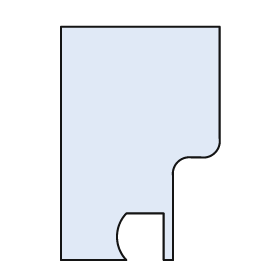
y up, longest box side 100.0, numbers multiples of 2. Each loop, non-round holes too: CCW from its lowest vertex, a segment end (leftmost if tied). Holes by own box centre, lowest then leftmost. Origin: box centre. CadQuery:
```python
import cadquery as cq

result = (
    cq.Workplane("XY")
    .moveTo(-34.0, -50.0)
    .lineTo(-6.0, -50.0)
    .threePointArc((-10.0, -40.0), (-6.0, -30.0))
    .lineTo(10.0, -30.0)
    .lineTo(10.0, -50.0)
    .lineTo(14.0, -50.0)
    .lineTo(14.0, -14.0)
    .threePointArc((16.0, -8.0), (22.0, -6.0))
    .lineTo(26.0, -6.0)
    .threePointArc((32.0, -4.0), (34.0, 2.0))
    .lineTo(34.0, 50.0)
    .lineTo(-34.0, 50.0)
    .close()
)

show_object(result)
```